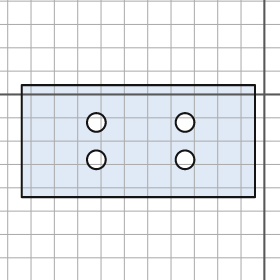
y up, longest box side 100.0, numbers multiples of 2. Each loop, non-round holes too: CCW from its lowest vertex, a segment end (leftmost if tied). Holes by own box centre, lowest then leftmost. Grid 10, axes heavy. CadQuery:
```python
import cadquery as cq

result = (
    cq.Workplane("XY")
    .moveTo(-104.0, -44.0)
    .lineTo(-4.0, -44.0)
    .lineTo(-4.0, 4.0)
    .lineTo(-104.0, 4.0)
    .close()
    .moveTo(-72.0, -28.0)
    .circle(4.0)
    .moveTo(-34.0, -28.0)
    .circle(4.0)
    .moveTo(-72.0, -12.0)
    .circle(4.0)
    .moveTo(-34.0, -12.0)
    .circle(4.0)
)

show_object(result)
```